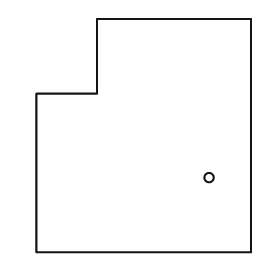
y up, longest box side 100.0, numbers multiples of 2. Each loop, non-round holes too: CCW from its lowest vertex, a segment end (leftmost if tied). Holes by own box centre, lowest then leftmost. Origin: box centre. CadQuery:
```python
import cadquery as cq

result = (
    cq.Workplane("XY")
    .moveTo(-46.0, -50.0)
    .lineTo(46.0, -50.0)
    .lineTo(46.0, 50.0)
    .lineTo(-20.0, 50.0)
    .lineTo(-20.0, 18.0)
    .lineTo(-46.0, 18.0)
    .close()
    .moveTo(28.0, -18.0)
    .circle(2.0)
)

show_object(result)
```